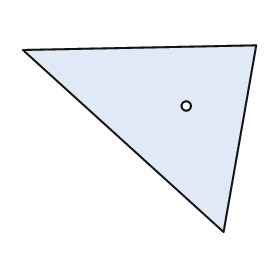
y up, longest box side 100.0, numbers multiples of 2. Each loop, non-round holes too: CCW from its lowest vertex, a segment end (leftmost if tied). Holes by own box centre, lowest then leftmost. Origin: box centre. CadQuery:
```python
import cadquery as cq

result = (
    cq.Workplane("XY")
    .moveTo(36.0, -40.0)
    .lineTo(50.0, 40.0)
    .lineTo(-50.0, 38.0)
    .close()
    .moveTo(20.0, 14.0)
    .circle(2.0)
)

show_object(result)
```